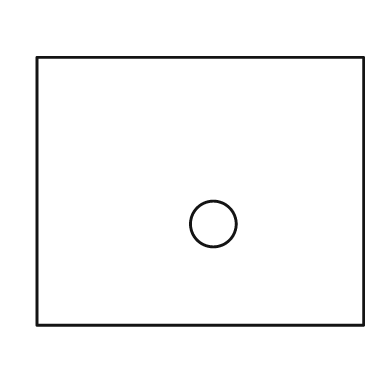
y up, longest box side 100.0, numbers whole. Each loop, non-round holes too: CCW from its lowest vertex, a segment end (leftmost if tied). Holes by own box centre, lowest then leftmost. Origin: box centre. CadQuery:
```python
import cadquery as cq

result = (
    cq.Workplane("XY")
    .moveTo(-50.0, -41.0)
    .lineTo(50.0, -41.0)
    .lineTo(50.0, 41.0)
    .lineTo(-50.0, 41.0)
    .close()
    .moveTo(4.0, -10.0)
    .circle(7.0)
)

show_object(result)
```